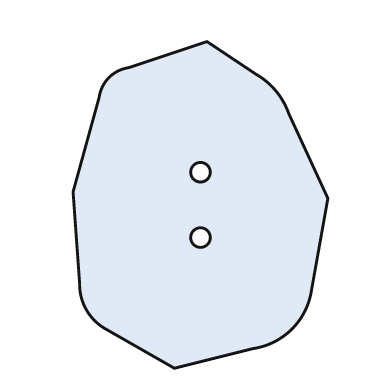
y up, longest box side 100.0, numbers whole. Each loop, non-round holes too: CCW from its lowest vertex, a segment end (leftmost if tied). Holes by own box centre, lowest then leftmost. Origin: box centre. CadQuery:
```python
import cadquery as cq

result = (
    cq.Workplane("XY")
    .moveTo(-8.0, -50.0)
    .lineTo(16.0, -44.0)
    .threePointArc((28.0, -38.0), (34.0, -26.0))
    .lineTo(39.0, 2.0)
    .lineTo(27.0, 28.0)
    .threePointArc((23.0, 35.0), (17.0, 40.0))
    .lineTo(2.0, 50.0)
    .lineTo(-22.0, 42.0)
    .threePointArc((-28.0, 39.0), (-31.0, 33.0))
    .lineTo(-39.0, 4.0)
    .lineTo(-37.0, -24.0)
    .threePointArc((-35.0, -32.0), (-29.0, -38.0))
    .close()
    .moveTo(0.0, -10.0)
    .circle(3.0)
    .moveTo(0.0, 10.0)
    .circle(3.0)
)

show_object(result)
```